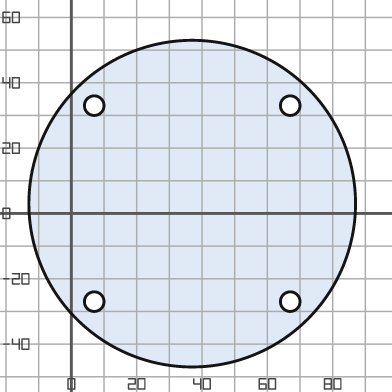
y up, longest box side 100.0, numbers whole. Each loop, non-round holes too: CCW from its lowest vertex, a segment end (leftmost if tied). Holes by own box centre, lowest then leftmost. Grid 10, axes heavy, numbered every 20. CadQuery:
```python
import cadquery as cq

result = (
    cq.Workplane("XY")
    .moveTo(37.0, 3.0)
    .circle(50.0)
    .moveTo(7.0, -27.0)
    .circle(3.0)
    .moveTo(67.0, -27.0)
    .circle(3.0)
    .moveTo(7.0, 33.0)
    .circle(3.0)
    .moveTo(67.0, 33.0)
    .circle(3.0)
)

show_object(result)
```